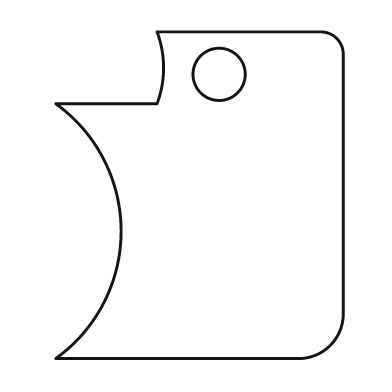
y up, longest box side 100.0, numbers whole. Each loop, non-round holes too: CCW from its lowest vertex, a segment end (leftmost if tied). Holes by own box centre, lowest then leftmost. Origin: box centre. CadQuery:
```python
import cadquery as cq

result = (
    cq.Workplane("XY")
    .moveTo(-44.0, -50.0)
    .lineTo(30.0, -50.0)
    .threePointArc((40.0, -46.0), (44.0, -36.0))
    .lineTo(44.0, 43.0)
    .threePointArc((42.0, 48.0), (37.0, 50.0))
    .lineTo(-13.0, 50.0)
    .threePointArc((-11.0, 39.0), (-13.0, 28.0))
    .lineTo(-44.0, 28.0)
    .threePointArc((-24.0, -11.0), (-44.0, -50.0))
    .close()
    .moveTo(6.0, 37.0)
    .circle(8.0)
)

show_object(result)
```